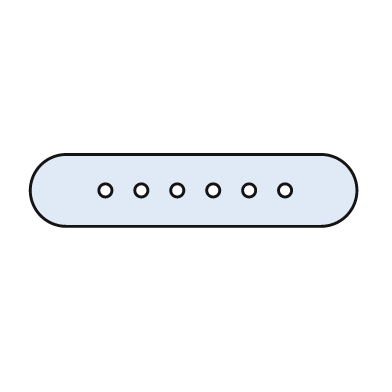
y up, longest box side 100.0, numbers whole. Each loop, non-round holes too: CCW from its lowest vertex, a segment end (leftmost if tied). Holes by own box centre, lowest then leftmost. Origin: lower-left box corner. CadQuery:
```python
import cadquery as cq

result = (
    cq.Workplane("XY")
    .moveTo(11.0, 0.0)
    .lineTo(89.0, 0.0)
    .threePointArc((100.0, 11.0), (89.0, 22.0))
    .lineTo(11.0, 22.0)
    .threePointArc((0.0, 11.0), (11.0, 0.0))
    .close()
    .moveTo(23.0, 11.0)
    .circle(2.0)
    .moveTo(34.0, 11.0)
    .circle(2.0)
    .moveTo(45.0, 11.0)
    .circle(2.0)
    .moveTo(56.0, 11.0)
    .circle(2.0)
    .moveTo(67.0, 11.0)
    .circle(2.0)
    .moveTo(78.0, 11.0)
    .circle(2.0)
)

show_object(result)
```